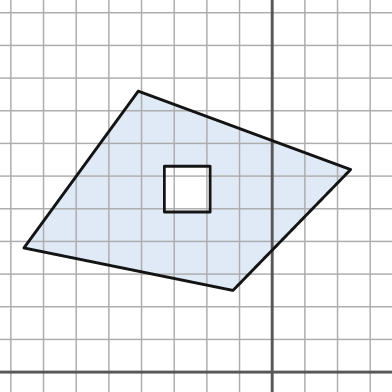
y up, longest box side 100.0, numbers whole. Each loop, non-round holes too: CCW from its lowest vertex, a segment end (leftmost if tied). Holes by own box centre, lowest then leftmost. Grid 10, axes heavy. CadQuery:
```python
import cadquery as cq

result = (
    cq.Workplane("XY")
    .moveTo(-12.0, 25.0)
    .lineTo(24.0, 62.0)
    .lineTo(-41.0, 86.0)
    .lineTo(-76.0, 38.0)
    .close()
    .moveTo(-33.0, 49.0)
    .lineTo(-19.0, 49.0)
    .lineTo(-19.0, 63.0)
    .lineTo(-33.0, 63.0)
    .close()
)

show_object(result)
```